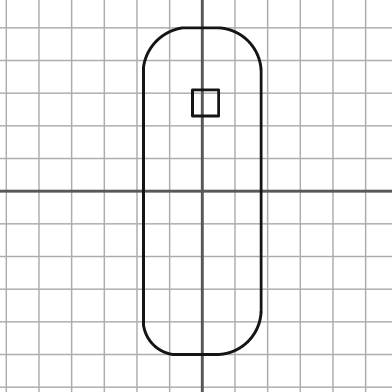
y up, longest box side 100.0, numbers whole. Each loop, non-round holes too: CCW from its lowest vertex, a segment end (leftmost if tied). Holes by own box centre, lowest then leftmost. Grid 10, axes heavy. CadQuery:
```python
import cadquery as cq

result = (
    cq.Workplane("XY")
    .moveTo(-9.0, -50.0)
    .lineTo(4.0, -50.0)
    .threePointArc((14.0, -46.0), (18.0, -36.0))
    .lineTo(18.0, 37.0)
    .threePointArc((14.0, 46.0), (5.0, 50.0))
    .lineTo(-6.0, 50.0)
    .threePointArc((-14.0, 46.0), (-18.0, 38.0))
    .lineTo(-18.0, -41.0)
    .threePointArc((-15.0, -47.0), (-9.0, -50.0))
    .close()
    .moveTo(-3.0, 23.0)
    .lineTo(5.0, 23.0)
    .lineTo(5.0, 31.0)
    .lineTo(-3.0, 31.0)
    .close()
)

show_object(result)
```